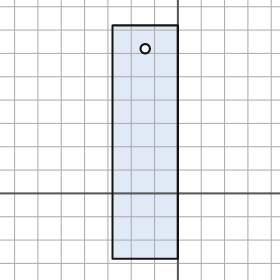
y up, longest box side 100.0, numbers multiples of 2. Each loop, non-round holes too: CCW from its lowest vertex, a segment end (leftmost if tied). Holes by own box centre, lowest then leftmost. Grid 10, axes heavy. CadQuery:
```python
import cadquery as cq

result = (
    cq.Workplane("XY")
    .moveTo(-28.0, -28.0)
    .lineTo(0.0, -28.0)
    .lineTo(0.0, 72.0)
    .lineTo(-28.0, 72.0)
    .close()
    .moveTo(-14.0, 62.0)
    .circle(2.0)
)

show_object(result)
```